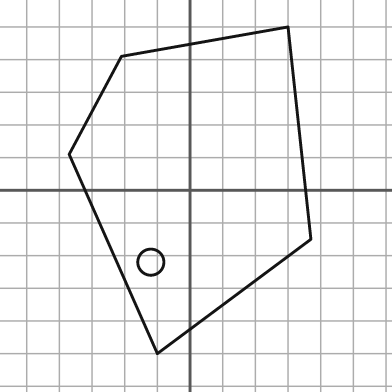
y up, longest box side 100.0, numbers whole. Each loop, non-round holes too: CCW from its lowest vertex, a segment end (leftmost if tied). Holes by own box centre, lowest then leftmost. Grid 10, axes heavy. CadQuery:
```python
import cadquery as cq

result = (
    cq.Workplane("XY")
    .moveTo(-10.0, -50.0)
    .lineTo(37.0, -15.0)
    .lineTo(30.0, 50.0)
    .lineTo(-21.0, 41.0)
    .lineTo(-37.0, 11.0)
    .close()
    .moveTo(-12.0, -22.0)
    .circle(4.0)
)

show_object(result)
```